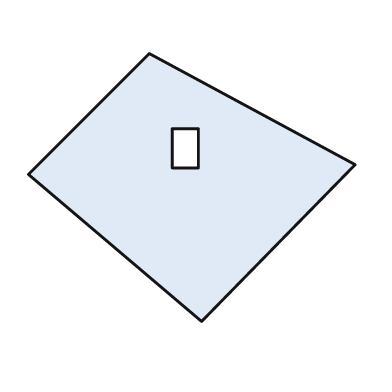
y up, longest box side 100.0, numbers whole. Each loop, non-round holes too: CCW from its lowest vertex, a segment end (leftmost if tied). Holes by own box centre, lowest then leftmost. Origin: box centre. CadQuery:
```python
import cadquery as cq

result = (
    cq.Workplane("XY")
    .moveTo(3.0, -41.0)
    .lineTo(50.0, 7.0)
    .lineTo(-13.0, 41.0)
    .lineTo(-50.0, 4.0)
    .close()
    .moveTo(-6.0, 6.0)
    .lineTo(2.0, 6.0)
    .lineTo(2.0, 18.0)
    .lineTo(-6.0, 18.0)
    .close()
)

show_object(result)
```